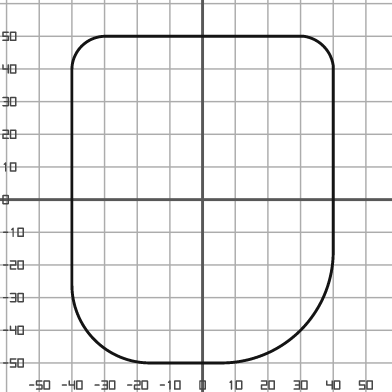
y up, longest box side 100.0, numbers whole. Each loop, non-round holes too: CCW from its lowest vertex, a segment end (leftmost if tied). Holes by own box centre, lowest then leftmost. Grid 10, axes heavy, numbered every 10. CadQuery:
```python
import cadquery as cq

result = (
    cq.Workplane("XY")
    .moveTo(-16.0, -50.0)
    .lineTo(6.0, -50.0)
    .threePointArc((30.0, -40.0), (40.0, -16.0))
    .lineTo(40.0, 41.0)
    .threePointArc((37.0, 47.0), (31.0, 50.0))
    .lineTo(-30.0, 50.0)
    .threePointArc((-37.0, 47.0), (-40.0, 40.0))
    .lineTo(-40.0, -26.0)
    .threePointArc((-33.0, -43.0), (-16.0, -50.0))
    .close()
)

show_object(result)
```